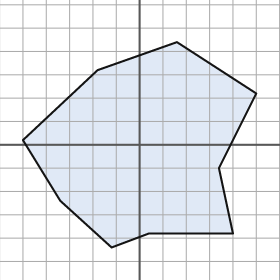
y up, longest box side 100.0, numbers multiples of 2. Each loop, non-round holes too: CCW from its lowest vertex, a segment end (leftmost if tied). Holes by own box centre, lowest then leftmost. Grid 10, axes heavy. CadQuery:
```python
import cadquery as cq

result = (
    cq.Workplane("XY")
    .moveTo(-12.0, -44.0)
    .lineTo(4.0, -38.0)
    .lineTo(40.0, -38.0)
    .lineTo(34.0, -10.0)
    .lineTo(50.0, 22.0)
    .lineTo(16.0, 44.0)
    .lineTo(-18.0, 32.0)
    .lineTo(-50.0, 2.0)
    .lineTo(-34.0, -24.0)
    .close()
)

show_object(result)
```